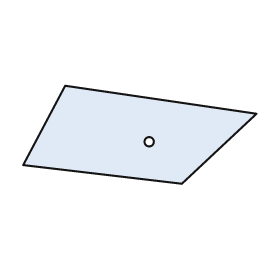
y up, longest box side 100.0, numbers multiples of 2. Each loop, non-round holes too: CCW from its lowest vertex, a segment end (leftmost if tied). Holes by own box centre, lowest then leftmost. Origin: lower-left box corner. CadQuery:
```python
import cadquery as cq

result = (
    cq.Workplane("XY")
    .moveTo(68.0, 0.0)
    .lineTo(100.0, 30.0)
    .lineTo(18.0, 42.0)
    .lineTo(0.0, 8.0)
    .close()
    .moveTo(54.0, 18.0)
    .circle(2.0)
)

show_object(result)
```